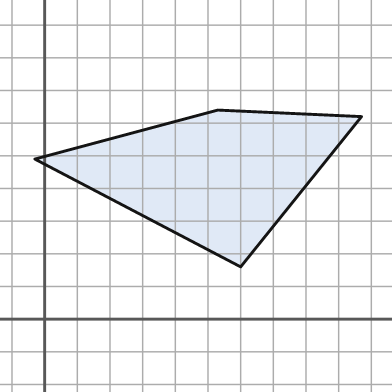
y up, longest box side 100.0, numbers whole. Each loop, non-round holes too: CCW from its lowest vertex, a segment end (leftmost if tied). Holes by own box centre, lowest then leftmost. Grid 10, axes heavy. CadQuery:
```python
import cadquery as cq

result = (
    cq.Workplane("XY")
    .moveTo(60.0, 16.0)
    .lineTo(97.0, 62.0)
    .lineTo(53.0, 64.0)
    .lineTo(-3.0, 49.0)
    .close()
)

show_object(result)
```